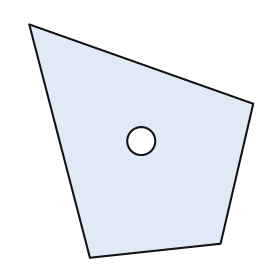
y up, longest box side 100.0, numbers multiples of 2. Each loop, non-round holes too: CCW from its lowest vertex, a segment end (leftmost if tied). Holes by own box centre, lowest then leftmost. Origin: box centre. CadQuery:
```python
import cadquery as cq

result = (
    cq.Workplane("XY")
    .moveTo(-22.0, -50.0)
    .lineTo(34.0, -44.0)
    .lineTo(48.0, 16.0)
    .lineTo(-48.0, 50.0)
    .close()
    .moveTo(0.0, 0.0)
    .circle(6.0)
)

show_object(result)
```